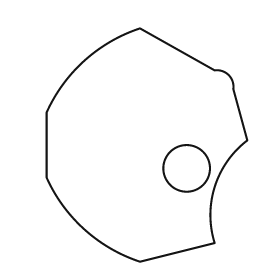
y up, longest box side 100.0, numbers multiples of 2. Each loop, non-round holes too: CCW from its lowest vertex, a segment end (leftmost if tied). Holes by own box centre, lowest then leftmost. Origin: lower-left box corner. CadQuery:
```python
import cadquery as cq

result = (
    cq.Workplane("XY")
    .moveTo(40.0, 0.0)
    .lineTo(72.0, 8.0)
    .threePointArc((72.0, 32.0), (86.0, 52.0))
    .lineTo(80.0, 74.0)
    .threePointArc((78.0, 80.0), (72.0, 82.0))
    .lineTo(40.0, 100.0)
    .threePointArc((16.0, 86.0), (0.0, 64.0))
    .lineTo(0.0, 36.0)
    .threePointArc((16.0, 14.0), (40.0, 0.0))
    .close()
    .moveTo(60.0, 40.0)
    .circle(10.0)
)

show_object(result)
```